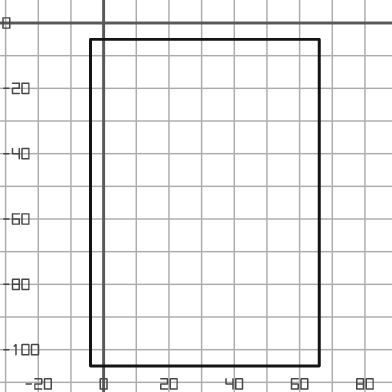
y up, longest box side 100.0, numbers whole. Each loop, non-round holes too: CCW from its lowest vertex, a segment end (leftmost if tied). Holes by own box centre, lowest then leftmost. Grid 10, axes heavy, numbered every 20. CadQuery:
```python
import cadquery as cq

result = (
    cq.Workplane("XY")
    .moveTo(-4.0, -105.0)
    .lineTo(66.0, -105.0)
    .lineTo(66.0, -5.0)
    .lineTo(-4.0, -5.0)
    .close()
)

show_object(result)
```